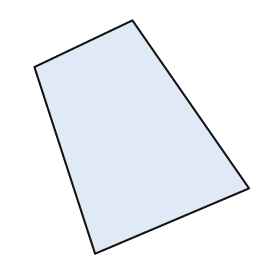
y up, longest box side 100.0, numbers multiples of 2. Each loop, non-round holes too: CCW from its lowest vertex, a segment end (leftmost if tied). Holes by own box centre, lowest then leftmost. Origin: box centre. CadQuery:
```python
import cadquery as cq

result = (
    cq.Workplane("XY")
    .moveTo(-20.0, -50.0)
    .lineTo(46.0, -22.0)
    .lineTo(-4.0, 50.0)
    .lineTo(-46.0, 30.0)
    .close()
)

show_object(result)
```